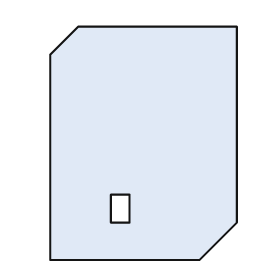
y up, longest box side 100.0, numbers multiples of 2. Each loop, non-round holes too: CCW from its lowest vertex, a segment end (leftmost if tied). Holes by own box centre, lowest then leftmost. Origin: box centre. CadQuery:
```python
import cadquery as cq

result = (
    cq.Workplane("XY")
    .moveTo(-40.0, -50.0)
    .lineTo(24.0, -50.0)
    .lineTo(40.0, -34.0)
    .lineTo(40.0, 50.0)
    .lineTo(-28.0, 50.0)
    .lineTo(-40.0, 38.0)
    .close()
    .moveTo(-14.0, -34.0)
    .lineTo(-6.0, -34.0)
    .lineTo(-6.0, -22.0)
    .lineTo(-14.0, -22.0)
    .close()
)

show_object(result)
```